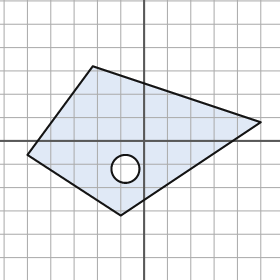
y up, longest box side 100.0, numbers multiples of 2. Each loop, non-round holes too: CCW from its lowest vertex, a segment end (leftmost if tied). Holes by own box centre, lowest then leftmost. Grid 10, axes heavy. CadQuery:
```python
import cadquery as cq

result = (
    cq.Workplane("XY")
    .moveTo(-10.0, -32.0)
    .lineTo(50.0, 8.0)
    .lineTo(-22.0, 32.0)
    .lineTo(-50.0, -6.0)
    .close()
    .moveTo(-8.0, -12.0)
    .circle(6.0)
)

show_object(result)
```